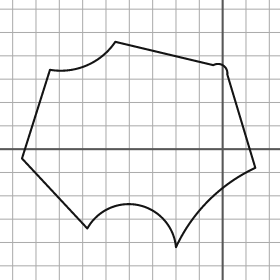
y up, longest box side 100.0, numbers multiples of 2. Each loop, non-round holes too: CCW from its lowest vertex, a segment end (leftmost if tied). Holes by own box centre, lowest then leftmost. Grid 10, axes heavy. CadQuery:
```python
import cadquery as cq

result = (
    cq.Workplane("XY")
    .moveTo(-20.0, -42.0)
    .threePointArc((-6.0, -22.0), (14.0, -8.0))
    .lineTo(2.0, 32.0)
    .threePointArc((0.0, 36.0), (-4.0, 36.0))
    .lineTo(-46.0, 46.0)
    .threePointArc((-58.0, 36.0), (-74.0, 34.0))
    .lineTo(-86.0, -4.0)
    .lineTo(-58.0, -34.0)
    .threePointArc((-36.0, -24.0), (-20.0, -42.0))
    .close()
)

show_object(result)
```